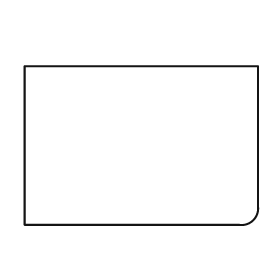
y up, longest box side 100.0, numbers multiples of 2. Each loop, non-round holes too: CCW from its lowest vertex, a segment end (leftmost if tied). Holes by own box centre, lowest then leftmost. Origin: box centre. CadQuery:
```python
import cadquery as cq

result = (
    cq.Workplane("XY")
    .moveTo(-50.0, -34.0)
    .lineTo(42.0, -34.0)
    .threePointArc((48.0, -32.0), (50.0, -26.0))
    .lineTo(50.0, 34.0)
    .lineTo(-50.0, 34.0)
    .close()
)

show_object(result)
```